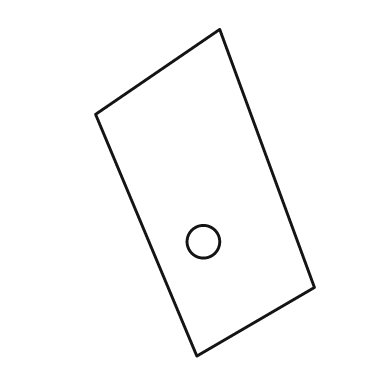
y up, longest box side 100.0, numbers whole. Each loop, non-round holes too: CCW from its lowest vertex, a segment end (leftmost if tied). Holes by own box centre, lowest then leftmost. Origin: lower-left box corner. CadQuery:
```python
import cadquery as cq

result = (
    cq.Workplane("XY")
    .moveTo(31.0, 0.0)
    .lineTo(67.0, 21.0)
    .lineTo(38.0, 100.0)
    .lineTo(0.0, 74.0)
    .close()
    .moveTo(33.0, 35.0)
    .circle(5.0)
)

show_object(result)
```